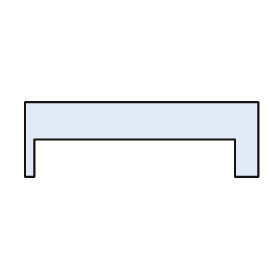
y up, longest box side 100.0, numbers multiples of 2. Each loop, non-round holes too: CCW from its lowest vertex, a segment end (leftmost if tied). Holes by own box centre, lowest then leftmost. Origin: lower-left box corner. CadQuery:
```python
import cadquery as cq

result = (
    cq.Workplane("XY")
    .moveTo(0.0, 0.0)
    .lineTo(4.0, 0.0)
    .lineTo(4.0, 16.0)
    .lineTo(90.0, 16.0)
    .lineTo(90.0, 0.0)
    .lineTo(100.0, 0.0)
    .lineTo(100.0, 32.0)
    .lineTo(0.0, 32.0)
    .close()
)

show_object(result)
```